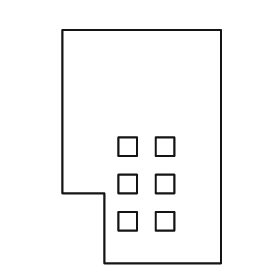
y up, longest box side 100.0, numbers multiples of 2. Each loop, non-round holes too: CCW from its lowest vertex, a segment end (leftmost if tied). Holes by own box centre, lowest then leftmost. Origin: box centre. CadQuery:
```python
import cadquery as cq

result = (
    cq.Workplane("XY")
    .moveTo(-16.0, -50.0)
    .lineTo(34.0, -50.0)
    .lineTo(34.0, 50.0)
    .lineTo(-34.0, 50.0)
    .lineTo(-34.0, -20.0)
    .lineTo(-16.0, -20.0)
    .close()
    .moveTo(-10.0, -36.0)
    .lineTo(-2.0, -36.0)
    .lineTo(-2.0, -28.0)
    .lineTo(-10.0, -28.0)
    .close()
    .moveTo(6.0, -36.0)
    .lineTo(14.0, -36.0)
    .lineTo(14.0, -28.0)
    .lineTo(6.0, -28.0)
    .close()
    .moveTo(-10.0, -20.0)
    .lineTo(-2.0, -20.0)
    .lineTo(-2.0, -12.0)
    .lineTo(-10.0, -12.0)
    .close()
    .moveTo(6.0, -20.0)
    .lineTo(14.0, -20.0)
    .lineTo(14.0, -12.0)
    .lineTo(6.0, -12.0)
    .close()
    .moveTo(-10.0, -4.0)
    .lineTo(-2.0, -4.0)
    .lineTo(-2.0, 4.0)
    .lineTo(-10.0, 4.0)
    .close()
    .moveTo(6.0, -4.0)
    .lineTo(14.0, -4.0)
    .lineTo(14.0, 4.0)
    .lineTo(6.0, 4.0)
    .close()
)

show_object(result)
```